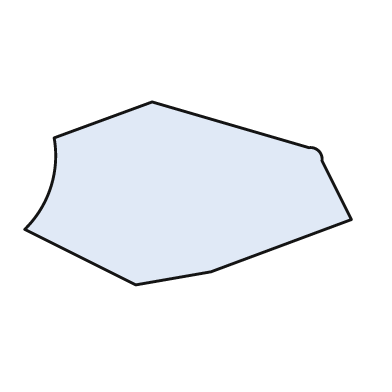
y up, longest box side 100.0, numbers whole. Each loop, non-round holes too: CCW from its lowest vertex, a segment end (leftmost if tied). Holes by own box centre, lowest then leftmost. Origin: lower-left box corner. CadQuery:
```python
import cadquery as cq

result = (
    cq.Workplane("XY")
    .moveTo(34.0, 0.0)
    .lineTo(57.0, 4.0)
    .lineTo(100.0, 20.0)
    .lineTo(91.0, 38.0)
    .threePointArc((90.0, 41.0), (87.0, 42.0))
    .lineTo(39.0, 56.0)
    .lineTo(9.0, 45.0)
    .threePointArc((8.0, 30.0), (0.0, 17.0))
    .close()
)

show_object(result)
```